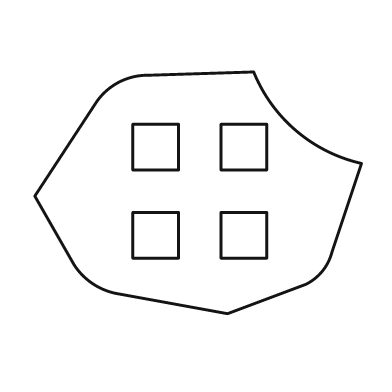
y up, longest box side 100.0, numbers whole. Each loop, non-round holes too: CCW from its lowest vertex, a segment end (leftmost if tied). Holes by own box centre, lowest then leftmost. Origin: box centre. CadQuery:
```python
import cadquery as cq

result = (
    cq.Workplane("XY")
    .moveTo(9.0, -37.0)
    .lineTo(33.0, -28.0)
    .threePointArc((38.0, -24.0), (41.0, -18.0))
    .lineTo(50.0, 9.0)
    .threePointArc((30.0, 19.0), (17.0, 37.0))
    .lineTo(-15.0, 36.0)
    .threePointArc((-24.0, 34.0), (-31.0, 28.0))
    .lineTo(-50.0, -1.0)
    .lineTo(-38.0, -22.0)
    .threePointArc((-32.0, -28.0), (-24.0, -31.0))
    .close()
    .moveTo(-20.0, -20.0)
    .lineTo(-6.0, -20.0)
    .lineTo(-6.0, -6.0)
    .lineTo(-20.0, -6.0)
    .close()
    .moveTo(7.0, -20.0)
    .lineTo(21.0, -20.0)
    .lineTo(21.0, -6.0)
    .lineTo(7.0, -6.0)
    .close()
    .moveTo(-20.0, 7.0)
    .lineTo(-6.0, 7.0)
    .lineTo(-6.0, 21.0)
    .lineTo(-20.0, 21.0)
    .close()
    .moveTo(7.0, 7.0)
    .lineTo(21.0, 7.0)
    .lineTo(21.0, 21.0)
    .lineTo(7.0, 21.0)
    .close()
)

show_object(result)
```